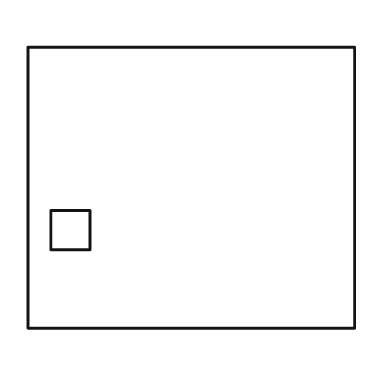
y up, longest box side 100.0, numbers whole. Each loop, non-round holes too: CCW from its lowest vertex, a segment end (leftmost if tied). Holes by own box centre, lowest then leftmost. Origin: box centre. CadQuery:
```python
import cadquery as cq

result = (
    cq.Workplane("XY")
    .moveTo(-50.0, -43.0)
    .lineTo(50.0, -43.0)
    .lineTo(50.0, 43.0)
    .lineTo(-50.0, 43.0)
    .close()
    .moveTo(-43.0, -19.0)
    .lineTo(-31.0, -19.0)
    .lineTo(-31.0, -7.0)
    .lineTo(-43.0, -7.0)
    .close()
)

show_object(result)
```